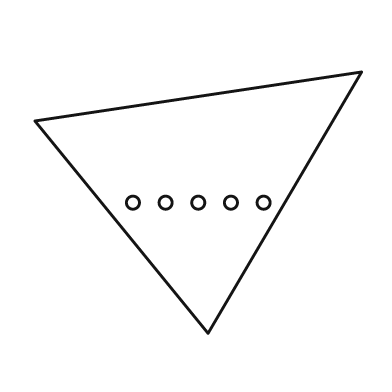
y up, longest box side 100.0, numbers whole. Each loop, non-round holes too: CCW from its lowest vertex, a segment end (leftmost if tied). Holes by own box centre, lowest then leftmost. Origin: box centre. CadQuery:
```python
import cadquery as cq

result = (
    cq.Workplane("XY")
    .moveTo(3.0, -40.0)
    .lineTo(50.0, 40.0)
    .lineTo(-50.0, 25.0)
    .close()
    .moveTo(-20.0, 0.0)
    .circle(2.0)
    .moveTo(-10.0, 0.0)
    .circle(2.0)
    .moveTo(0.0, 0.0)
    .circle(2.0)
    .moveTo(10.0, 0.0)
    .circle(2.0)
    .moveTo(20.0, 0.0)
    .circle(2.0)
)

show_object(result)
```